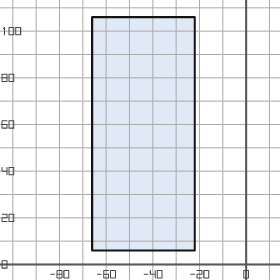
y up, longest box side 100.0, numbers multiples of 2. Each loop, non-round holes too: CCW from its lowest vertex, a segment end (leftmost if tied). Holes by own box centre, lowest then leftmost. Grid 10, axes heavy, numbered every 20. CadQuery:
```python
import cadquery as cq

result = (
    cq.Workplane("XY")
    .moveTo(-66.0, 6.0)
    .lineTo(-22.0, 6.0)
    .lineTo(-22.0, 106.0)
    .lineTo(-66.0, 106.0)
    .close()
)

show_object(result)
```